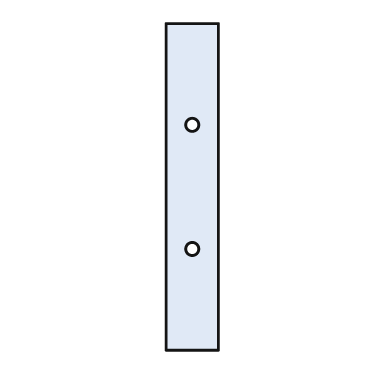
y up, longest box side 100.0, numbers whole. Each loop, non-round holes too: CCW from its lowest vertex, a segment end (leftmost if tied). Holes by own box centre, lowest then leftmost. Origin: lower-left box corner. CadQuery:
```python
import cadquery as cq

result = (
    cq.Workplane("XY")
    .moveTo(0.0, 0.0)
    .lineTo(16.0, 0.0)
    .lineTo(16.0, 100.0)
    .lineTo(0.0, 100.0)
    .close()
    .moveTo(8.0, 31.0)
    .circle(2.0)
    .moveTo(8.0, 69.0)
    .circle(2.0)
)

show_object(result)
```